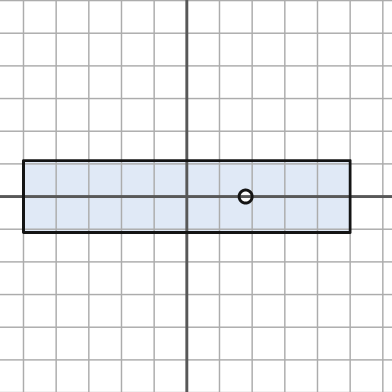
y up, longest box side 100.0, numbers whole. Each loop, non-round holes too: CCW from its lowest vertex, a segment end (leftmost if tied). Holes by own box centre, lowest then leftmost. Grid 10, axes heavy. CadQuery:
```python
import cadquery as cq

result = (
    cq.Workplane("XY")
    .moveTo(-50.0, -11.0)
    .lineTo(50.0, -11.0)
    .lineTo(50.0, 11.0)
    .lineTo(-50.0, 11.0)
    .close()
    .moveTo(18.0, 0.0)
    .circle(2.0)
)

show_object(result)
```